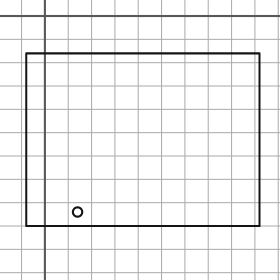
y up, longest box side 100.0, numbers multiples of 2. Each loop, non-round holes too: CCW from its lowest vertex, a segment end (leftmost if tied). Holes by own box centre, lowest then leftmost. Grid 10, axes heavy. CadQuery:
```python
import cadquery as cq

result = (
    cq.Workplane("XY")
    .moveTo(-8.0, -90.0)
    .lineTo(92.0, -90.0)
    .lineTo(92.0, -16.0)
    .lineTo(-8.0, -16.0)
    .close()
    .moveTo(14.0, -84.0)
    .circle(2.0)
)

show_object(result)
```